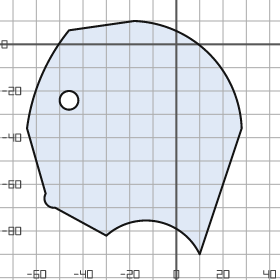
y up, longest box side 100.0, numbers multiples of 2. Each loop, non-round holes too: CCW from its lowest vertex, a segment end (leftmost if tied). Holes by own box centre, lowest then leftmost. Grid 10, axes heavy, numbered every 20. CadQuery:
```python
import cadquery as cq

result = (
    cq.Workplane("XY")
    .moveTo(10.0, -90.0)
    .lineTo(28.0, -36.0)
    .threePointArc((14.0, -4.0), (-18.0, 10.0))
    .lineTo(-46.0, 6.0)
    .threePointArc((-58.0, -14.0), (-64.0, -36.0))
    .lineTo(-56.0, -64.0)
    .threePointArc((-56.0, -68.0), (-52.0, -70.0))
    .lineTo(-30.0, -82.0)
    .threePointArc((-8.0, -76.0), (10.0, -90.0))
    .close()
    .moveTo(-46.0, -24.0)
    .circle(4.0)
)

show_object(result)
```